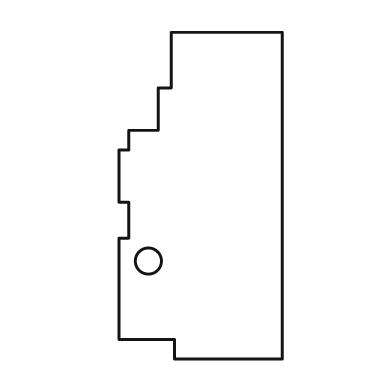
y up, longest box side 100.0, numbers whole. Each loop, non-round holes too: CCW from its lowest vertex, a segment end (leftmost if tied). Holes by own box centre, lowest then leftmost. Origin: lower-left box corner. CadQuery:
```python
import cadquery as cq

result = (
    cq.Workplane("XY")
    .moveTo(17.0, 0.0)
    .lineTo(50.0, 0.0)
    .lineTo(50.0, 100.0)
    .lineTo(16.0, 100.0)
    .lineTo(16.0, 83.0)
    .lineTo(12.0, 83.0)
    .lineTo(12.0, 70.0)
    .lineTo(3.0, 70.0)
    .lineTo(3.0, 64.0)
    .lineTo(0.0, 64.0)
    .lineTo(0.0, 48.0)
    .lineTo(3.0, 48.0)
    .lineTo(3.0, 37.0)
    .lineTo(0.0, 37.0)
    .lineTo(0.0, 6.0)
    .lineTo(17.0, 6.0)
    .close()
    .moveTo(9.0, 30.0)
    .circle(4.0)
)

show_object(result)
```